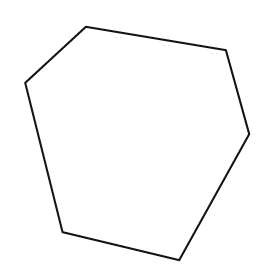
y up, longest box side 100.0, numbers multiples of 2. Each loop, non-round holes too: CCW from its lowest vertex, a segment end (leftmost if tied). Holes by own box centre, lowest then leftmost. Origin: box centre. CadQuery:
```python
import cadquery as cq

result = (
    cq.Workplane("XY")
    .moveTo(18.0, -50.0)
    .lineTo(48.0, 4.0)
    .lineTo(38.0, 40.0)
    .lineTo(-22.0, 50.0)
    .lineTo(-48.0, 26.0)
    .lineTo(-32.0, -38.0)
    .close()
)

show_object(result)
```